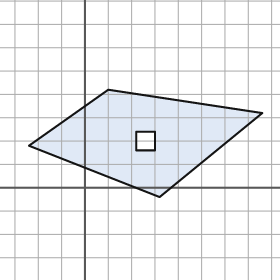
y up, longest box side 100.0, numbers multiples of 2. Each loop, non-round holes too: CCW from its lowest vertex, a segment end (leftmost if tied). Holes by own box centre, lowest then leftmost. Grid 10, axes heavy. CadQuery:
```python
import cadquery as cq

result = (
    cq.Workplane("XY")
    .moveTo(32.0, -4.0)
    .lineTo(76.0, 32.0)
    .lineTo(10.0, 42.0)
    .lineTo(-24.0, 18.0)
    .close()
    .moveTo(22.0, 16.0)
    .lineTo(30.0, 16.0)
    .lineTo(30.0, 24.0)
    .lineTo(22.0, 24.0)
    .close()
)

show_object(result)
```